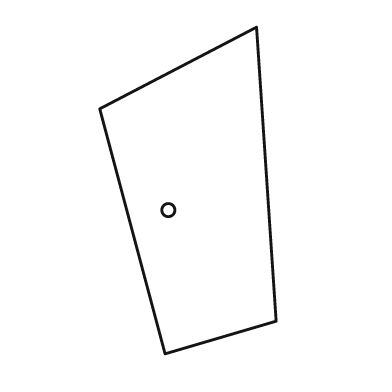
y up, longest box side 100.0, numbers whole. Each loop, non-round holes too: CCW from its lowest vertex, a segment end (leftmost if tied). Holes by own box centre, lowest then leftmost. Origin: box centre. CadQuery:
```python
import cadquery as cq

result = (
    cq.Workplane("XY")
    .moveTo(-7.0, -50.0)
    .lineTo(27.0, -40.0)
    .lineTo(21.0, 50.0)
    .lineTo(-27.0, 25.0)
    .close()
    .moveTo(-6.0, -6.0)
    .circle(2.0)
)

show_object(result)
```